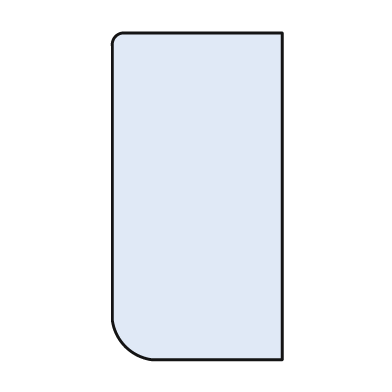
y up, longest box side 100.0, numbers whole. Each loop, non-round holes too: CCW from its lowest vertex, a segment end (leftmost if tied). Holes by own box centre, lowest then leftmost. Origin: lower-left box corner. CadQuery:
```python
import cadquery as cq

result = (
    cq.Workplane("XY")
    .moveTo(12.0, 0.0)
    .lineTo(52.0, 0.0)
    .lineTo(52.0, 100.0)
    .lineTo(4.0, 100.0)
    .threePointArc((1.0, 99.0), (0.0, 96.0))
    .lineTo(0.0, 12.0)
    .threePointArc((4.0, 4.0), (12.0, 0.0))
    .close()
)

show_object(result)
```